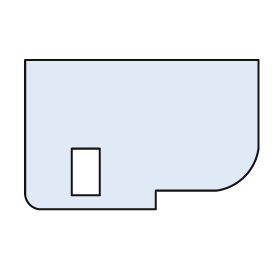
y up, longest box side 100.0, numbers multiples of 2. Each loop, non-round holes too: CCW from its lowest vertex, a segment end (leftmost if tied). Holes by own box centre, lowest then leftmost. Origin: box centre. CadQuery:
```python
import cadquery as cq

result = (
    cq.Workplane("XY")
    .moveTo(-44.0, -32.0)
    .lineTo(6.0, -32.0)
    .lineTo(6.0, -24.0)
    .lineTo(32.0, -24.0)
    .threePointArc((44.0, -18.0), (50.0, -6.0))
    .lineTo(50.0, 32.0)
    .lineTo(-50.0, 32.0)
    .lineTo(-50.0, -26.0)
    .threePointArc((-48.0, -30.0), (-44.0, -32.0))
    .close()
    .moveTo(-30.0, -26.0)
    .lineTo(-18.0, -26.0)
    .lineTo(-18.0, -6.0)
    .lineTo(-30.0, -6.0)
    .close()
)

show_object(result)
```